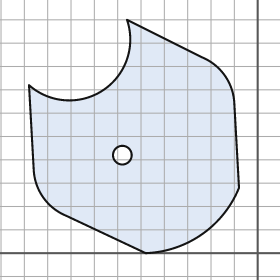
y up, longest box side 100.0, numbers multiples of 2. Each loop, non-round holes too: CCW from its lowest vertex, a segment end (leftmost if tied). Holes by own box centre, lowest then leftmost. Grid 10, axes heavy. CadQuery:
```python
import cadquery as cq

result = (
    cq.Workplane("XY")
    .moveTo(-48.0, 0.0)
    .threePointArc((-24.0, 8.0), (-8.0, 28.0))
    .lineTo(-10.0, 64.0)
    .threePointArc((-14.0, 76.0), (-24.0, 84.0))
    .lineTo(-56.0, 100.0)
    .threePointArc((-66.0, 70.0), (-98.0, 72.0))
    .lineTo(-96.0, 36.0)
    .threePointArc((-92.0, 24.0), (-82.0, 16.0))
    .close()
    .moveTo(-58.0, 42.0)
    .circle(4.0)
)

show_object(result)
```